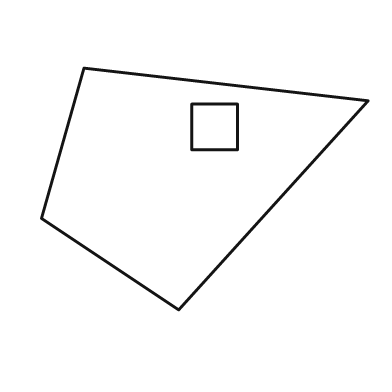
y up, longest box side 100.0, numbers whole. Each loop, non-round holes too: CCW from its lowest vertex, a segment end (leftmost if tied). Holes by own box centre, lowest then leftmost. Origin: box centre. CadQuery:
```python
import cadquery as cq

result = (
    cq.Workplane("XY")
    .moveTo(-8.0, -37.0)
    .lineTo(50.0, 27.0)
    .lineTo(-37.0, 37.0)
    .lineTo(-50.0, -9.0)
    .close()
    .moveTo(-4.0, 12.0)
    .lineTo(10.0, 12.0)
    .lineTo(10.0, 26.0)
    .lineTo(-4.0, 26.0)
    .close()
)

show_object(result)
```